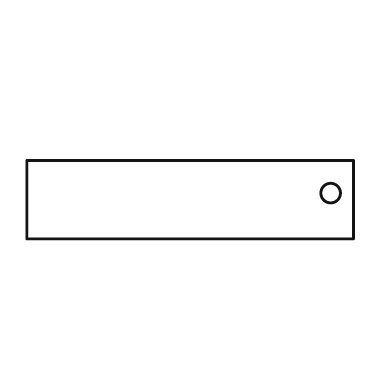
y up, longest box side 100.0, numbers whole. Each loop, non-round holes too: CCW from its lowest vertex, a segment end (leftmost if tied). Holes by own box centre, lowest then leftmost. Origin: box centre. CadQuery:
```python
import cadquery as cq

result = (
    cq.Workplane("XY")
    .moveTo(-50.0, -12.0)
    .lineTo(50.0, -12.0)
    .lineTo(50.0, 12.0)
    .lineTo(-50.0, 12.0)
    .close()
    .moveTo(43.0, 2.0)
    .circle(3.0)
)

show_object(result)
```